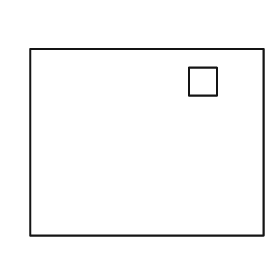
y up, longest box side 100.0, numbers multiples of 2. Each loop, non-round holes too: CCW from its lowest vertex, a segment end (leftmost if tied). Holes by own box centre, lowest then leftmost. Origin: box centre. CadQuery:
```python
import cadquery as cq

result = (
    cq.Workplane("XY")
    .moveTo(-50.0, -40.0)
    .lineTo(50.0, -40.0)
    .lineTo(50.0, 40.0)
    .lineTo(-50.0, 40.0)
    .close()
    .moveTo(18.0, 20.0)
    .lineTo(30.0, 20.0)
    .lineTo(30.0, 32.0)
    .lineTo(18.0, 32.0)
    .close()
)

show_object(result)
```